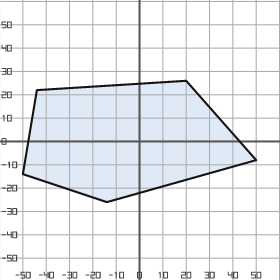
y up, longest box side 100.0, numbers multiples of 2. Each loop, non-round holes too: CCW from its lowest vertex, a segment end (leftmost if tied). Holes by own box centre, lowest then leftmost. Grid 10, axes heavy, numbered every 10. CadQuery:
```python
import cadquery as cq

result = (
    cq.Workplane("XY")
    .moveTo(-14.0, -26.0)
    .lineTo(50.0, -8.0)
    .lineTo(20.0, 26.0)
    .lineTo(-44.0, 22.0)
    .lineTo(-50.0, -14.0)
    .close()
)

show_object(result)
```